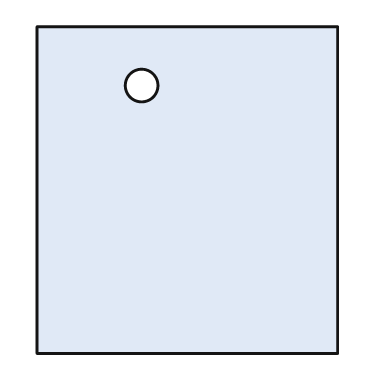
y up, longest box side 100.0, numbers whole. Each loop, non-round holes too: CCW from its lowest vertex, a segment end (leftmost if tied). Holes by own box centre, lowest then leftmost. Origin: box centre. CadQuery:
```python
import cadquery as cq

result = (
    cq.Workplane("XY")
    .moveTo(-46.0, -50.0)
    .lineTo(46.0, -50.0)
    .lineTo(46.0, 50.0)
    .lineTo(-46.0, 50.0)
    .close()
    .moveTo(-14.0, 32.0)
    .circle(5.0)
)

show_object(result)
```